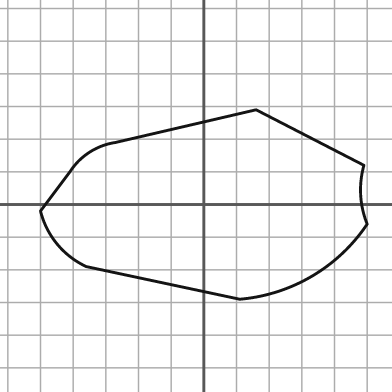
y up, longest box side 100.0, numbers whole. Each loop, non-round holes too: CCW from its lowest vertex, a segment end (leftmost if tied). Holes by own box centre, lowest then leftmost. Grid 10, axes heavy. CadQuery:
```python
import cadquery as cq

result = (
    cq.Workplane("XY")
    .moveTo(11.0, -29.0)
    .threePointArc((33.0, -22.0), (50.0, -6.0))
    .threePointArc((48.0, 3.0), (49.0, 12.0))
    .lineTo(16.0, 29.0)
    .lineTo(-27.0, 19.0)
    .threePointArc((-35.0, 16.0), (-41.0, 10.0))
    .lineTo(-50.0, -2.0)
    .threePointArc((-45.0, -12.0), (-36.0, -19.0))
    .close()
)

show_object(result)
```